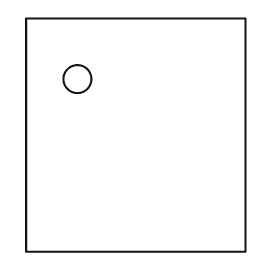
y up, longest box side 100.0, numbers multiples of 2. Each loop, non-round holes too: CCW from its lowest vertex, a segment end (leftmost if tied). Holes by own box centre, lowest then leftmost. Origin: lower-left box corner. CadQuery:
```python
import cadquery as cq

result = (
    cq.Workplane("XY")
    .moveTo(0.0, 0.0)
    .lineTo(94.0, 0.0)
    .lineTo(94.0, 100.0)
    .lineTo(0.0, 100.0)
    .close()
    .moveTo(22.0, 74.0)
    .circle(6.0)
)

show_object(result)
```